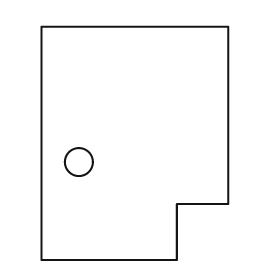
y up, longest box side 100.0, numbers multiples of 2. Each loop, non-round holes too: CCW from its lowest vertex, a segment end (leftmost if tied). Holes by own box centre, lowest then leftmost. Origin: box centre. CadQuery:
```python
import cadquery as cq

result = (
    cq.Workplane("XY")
    .moveTo(-40.0, -50.0)
    .lineTo(18.0, -50.0)
    .lineTo(18.0, -26.0)
    .lineTo(40.0, -26.0)
    .lineTo(40.0, 50.0)
    .lineTo(-40.0, 50.0)
    .close()
    .moveTo(-24.0, -8.0)
    .circle(6.0)
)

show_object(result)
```